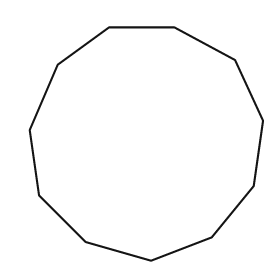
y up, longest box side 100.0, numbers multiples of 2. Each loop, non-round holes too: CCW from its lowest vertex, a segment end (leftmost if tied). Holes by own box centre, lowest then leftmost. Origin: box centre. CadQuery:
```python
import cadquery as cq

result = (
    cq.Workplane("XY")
    .moveTo(2.0, -50.0)
    .lineTo(28.0, -40.0)
    .lineTo(46.0, -18.0)
    .lineTo(50.0, 10.0)
    .lineTo(38.0, 36.0)
    .lineTo(12.0, 50.0)
    .lineTo(-16.0, 50.0)
    .lineTo(-38.0, 34.0)
    .lineTo(-50.0, 6.0)
    .lineTo(-46.0, -22.0)
    .lineTo(-26.0, -42.0)
    .close()
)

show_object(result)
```